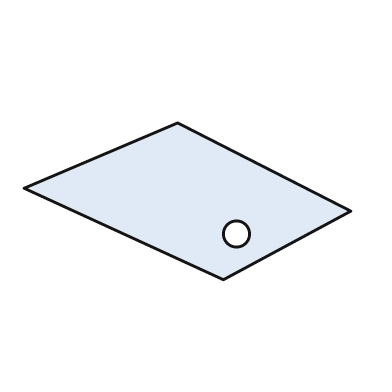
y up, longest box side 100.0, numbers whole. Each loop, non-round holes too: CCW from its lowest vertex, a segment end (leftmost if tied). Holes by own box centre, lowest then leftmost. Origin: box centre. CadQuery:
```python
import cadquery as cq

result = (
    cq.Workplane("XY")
    .moveTo(11.0, -24.0)
    .lineTo(50.0, -3.0)
    .lineTo(-3.0, 24.0)
    .lineTo(-50.0, 4.0)
    .close()
    .moveTo(15.0, -10.0)
    .circle(4.0)
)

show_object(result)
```